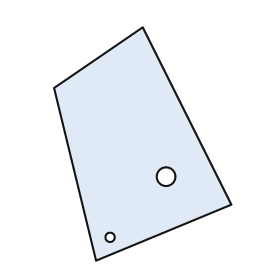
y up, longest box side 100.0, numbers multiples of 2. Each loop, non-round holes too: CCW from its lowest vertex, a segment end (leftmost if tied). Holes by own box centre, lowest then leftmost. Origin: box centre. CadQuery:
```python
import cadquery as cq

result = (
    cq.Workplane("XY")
    .moveTo(-20.0, -50.0)
    .lineTo(38.0, -26.0)
    .lineTo(0.0, 50.0)
    .lineTo(-38.0, 24.0)
    .close()
    .moveTo(-14.0, -40.0)
    .circle(2.0)
    .moveTo(10.0, -14.0)
    .circle(4.0)
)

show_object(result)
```